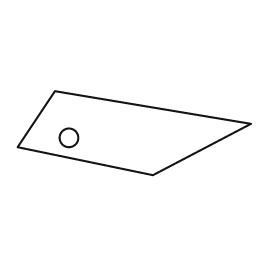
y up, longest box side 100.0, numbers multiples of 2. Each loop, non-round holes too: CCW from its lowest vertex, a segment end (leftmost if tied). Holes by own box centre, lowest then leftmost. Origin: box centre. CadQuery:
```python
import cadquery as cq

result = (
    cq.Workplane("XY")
    .moveTo(8.0, -18.0)
    .lineTo(50.0, 4.0)
    .lineTo(-34.0, 18.0)
    .lineTo(-50.0, -6.0)
    .close()
    .moveTo(-28.0, -2.0)
    .circle(4.0)
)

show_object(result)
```